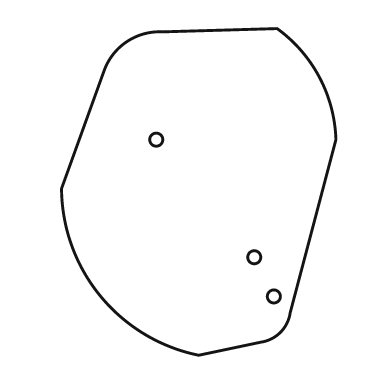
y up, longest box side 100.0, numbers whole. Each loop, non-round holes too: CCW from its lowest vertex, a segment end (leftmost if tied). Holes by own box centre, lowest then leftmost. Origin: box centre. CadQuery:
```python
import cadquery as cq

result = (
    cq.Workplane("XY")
    .moveTo(0.0, -50.0)
    .lineTo(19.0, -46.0)
    .threePointArc((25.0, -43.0), (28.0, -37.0))
    .lineTo(42.0, 16.0)
    .threePointArc((37.0, 35.0), (24.0, 50.0))
    .lineTo(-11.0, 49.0)
    .threePointArc((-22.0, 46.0), (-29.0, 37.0))
    .lineTo(-42.0, 1.0)
    .threePointArc((-30.0, -32.0), (0.0, -50.0))
    .close()
    .moveTo(23.0, -32.0)
    .circle(2.0)
    .moveTo(17.0, -20.0)
    .circle(2.0)
    .moveTo(-13.0, 16.0)
    .circle(2.0)
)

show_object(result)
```